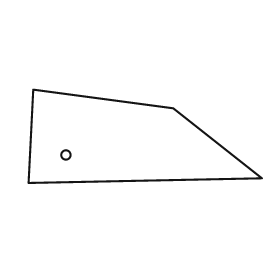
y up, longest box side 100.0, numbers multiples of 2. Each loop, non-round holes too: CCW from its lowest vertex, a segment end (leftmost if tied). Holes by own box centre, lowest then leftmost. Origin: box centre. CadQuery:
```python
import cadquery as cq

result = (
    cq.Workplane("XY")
    .moveTo(-50.0, -20.0)
    .lineTo(50.0, -18.0)
    .lineTo(12.0, 12.0)
    .lineTo(-48.0, 20.0)
    .close()
    .moveTo(-34.0, -8.0)
    .circle(2.0)
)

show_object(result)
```